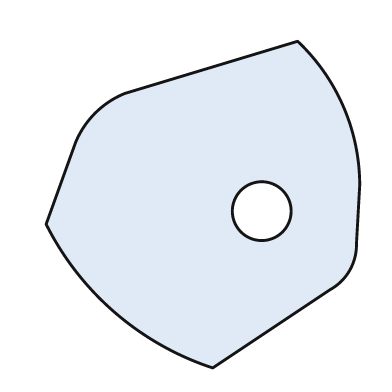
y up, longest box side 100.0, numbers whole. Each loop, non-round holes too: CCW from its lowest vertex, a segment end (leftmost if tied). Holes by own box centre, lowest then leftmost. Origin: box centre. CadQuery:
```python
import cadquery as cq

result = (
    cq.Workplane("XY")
    .moveTo(3.0, -50.0)
    .lineTo(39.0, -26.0)
    .threePointArc((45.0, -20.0), (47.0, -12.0))
    .lineTo(48.0, 6.0)
    .threePointArc((43.0, 30.0), (29.0, 50.0))
    .lineTo(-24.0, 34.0)
    .threePointArc((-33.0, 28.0), (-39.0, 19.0))
    .lineTo(-48.0, -6.0)
    .threePointArc((-27.0, -33.0), (3.0, -50.0))
    .close()
    .moveTo(18.0, -2.0)
    .circle(9.0)
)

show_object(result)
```